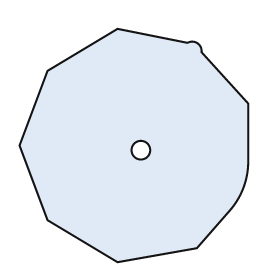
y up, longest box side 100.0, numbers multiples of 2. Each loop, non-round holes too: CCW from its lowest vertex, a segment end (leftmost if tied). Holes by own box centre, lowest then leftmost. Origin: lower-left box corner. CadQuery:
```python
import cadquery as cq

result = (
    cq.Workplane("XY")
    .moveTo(42.0, 0.0)
    .lineTo(76.0, 6.0)
    .lineTo(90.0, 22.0)
    .threePointArc((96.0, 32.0), (98.0, 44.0))
    .lineTo(98.0, 68.0)
    .lineTo(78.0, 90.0)
    .threePointArc((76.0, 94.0), (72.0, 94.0))
    .lineTo(42.0, 100.0)
    .lineTo(12.0, 82.0)
    .lineTo(0.0, 50.0)
    .lineTo(12.0, 18.0)
    .close()
    .moveTo(52.0, 48.0)
    .circle(4.0)
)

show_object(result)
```